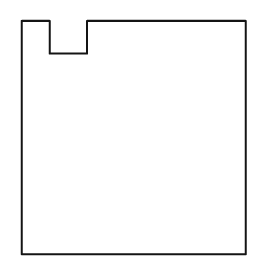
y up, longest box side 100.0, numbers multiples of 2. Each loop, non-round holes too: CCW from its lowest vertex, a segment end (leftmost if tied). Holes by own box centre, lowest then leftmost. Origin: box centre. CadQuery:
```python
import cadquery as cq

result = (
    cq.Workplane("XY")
    .moveTo(-48.0, -50.0)
    .lineTo(48.0, -50.0)
    .lineTo(48.0, 50.0)
    .lineTo(-20.0, 50.0)
    .lineTo(-20.0, 36.0)
    .lineTo(-36.0, 36.0)
    .lineTo(-36.0, 50.0)
    .lineTo(-48.0, 50.0)
    .close()
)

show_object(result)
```